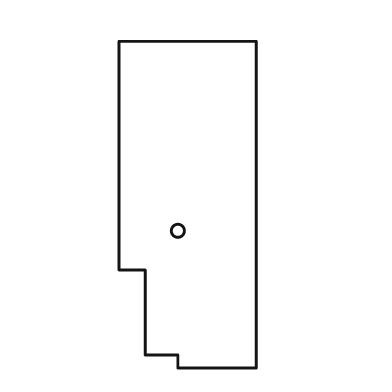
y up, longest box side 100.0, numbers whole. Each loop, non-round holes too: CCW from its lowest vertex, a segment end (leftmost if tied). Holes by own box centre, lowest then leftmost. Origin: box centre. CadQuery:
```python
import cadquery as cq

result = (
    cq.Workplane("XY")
    .moveTo(-3.0, -50.0)
    .lineTo(21.0, -50.0)
    .lineTo(21.0, 50.0)
    .lineTo(-21.0, 50.0)
    .lineTo(-21.0, -20.0)
    .lineTo(-13.0, -20.0)
    .lineTo(-13.0, -46.0)
    .lineTo(-3.0, -46.0)
    .close()
    .moveTo(-3.0, -8.0)
    .circle(2.0)
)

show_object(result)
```